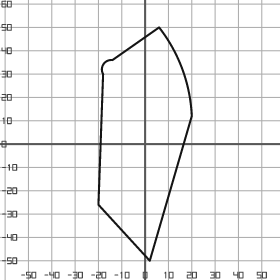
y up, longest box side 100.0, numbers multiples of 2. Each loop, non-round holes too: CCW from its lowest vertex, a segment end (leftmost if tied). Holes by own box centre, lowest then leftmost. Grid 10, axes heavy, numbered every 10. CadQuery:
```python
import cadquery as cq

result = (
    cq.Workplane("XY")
    .moveTo(2.0, -50.0)
    .lineTo(20.0, 12.0)
    .threePointArc((16.0, 32.0), (6.0, 50.0))
    .lineTo(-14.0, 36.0)
    .threePointArc((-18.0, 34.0), (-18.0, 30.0))
    .lineTo(-20.0, -26.0)
    .close()
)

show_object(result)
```